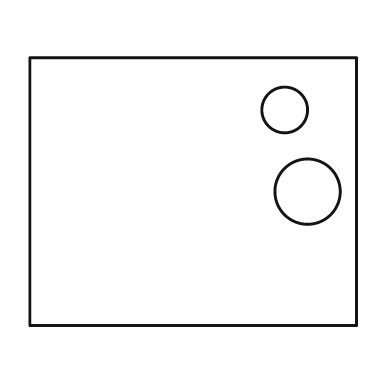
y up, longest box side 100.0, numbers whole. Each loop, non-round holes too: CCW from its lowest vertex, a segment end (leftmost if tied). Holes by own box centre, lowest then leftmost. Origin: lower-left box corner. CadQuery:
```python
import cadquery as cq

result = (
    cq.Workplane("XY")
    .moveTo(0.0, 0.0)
    .lineTo(100.0, 0.0)
    .lineTo(100.0, 82.0)
    .lineTo(0.0, 82.0)
    .close()
    .moveTo(85.0, 41.0)
    .circle(10.0)
    .moveTo(78.0, 66.0)
    .circle(7.0)
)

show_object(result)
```